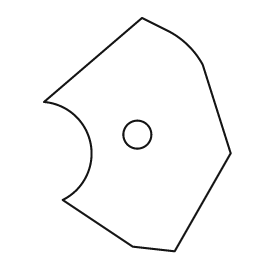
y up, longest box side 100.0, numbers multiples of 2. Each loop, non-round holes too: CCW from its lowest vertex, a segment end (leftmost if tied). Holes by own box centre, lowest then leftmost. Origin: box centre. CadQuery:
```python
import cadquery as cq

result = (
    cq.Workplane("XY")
    .moveTo(16.0, -50.0)
    .lineTo(40.0, -8.0)
    .lineTo(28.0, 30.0)
    .threePointArc((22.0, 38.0), (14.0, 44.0))
    .lineTo(2.0, 50.0)
    .lineTo(-40.0, 14.0)
    .threePointArc((-20.0, -4.0), (-32.0, -28.0))
    .lineTo(-2.0, -48.0)
    .close()
    .moveTo(0.0, 0.0)
    .circle(6.0)
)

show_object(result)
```